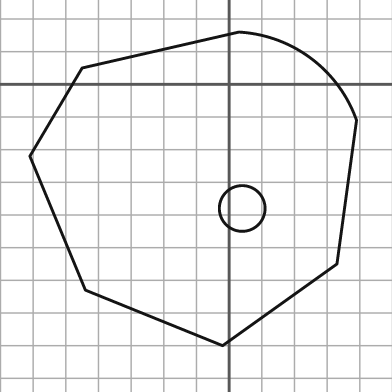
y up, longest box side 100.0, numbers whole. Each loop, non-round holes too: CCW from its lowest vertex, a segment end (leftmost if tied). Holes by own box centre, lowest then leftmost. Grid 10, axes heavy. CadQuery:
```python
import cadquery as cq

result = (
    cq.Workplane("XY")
    .moveTo(-2.0, -80.0)
    .lineTo(33.0, -55.0)
    .lineTo(39.0, -11.0)
    .threePointArc((25.0, 8.0), (3.0, 16.0))
    .lineTo(-45.0, 5.0)
    .lineTo(-61.0, -22.0)
    .lineTo(-44.0, -63.0)
    .close()
    .moveTo(4.0, -38.0)
    .circle(7.0)
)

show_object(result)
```